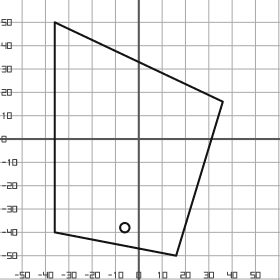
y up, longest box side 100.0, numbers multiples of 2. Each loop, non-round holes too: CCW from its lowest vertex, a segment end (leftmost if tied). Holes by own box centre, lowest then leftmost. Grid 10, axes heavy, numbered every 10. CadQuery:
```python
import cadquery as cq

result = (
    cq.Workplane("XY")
    .moveTo(16.0, -50.0)
    .lineTo(36.0, 16.0)
    .lineTo(-36.0, 50.0)
    .lineTo(-36.0, -40.0)
    .close()
    .moveTo(-6.0, -38.0)
    .circle(2.0)
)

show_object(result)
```